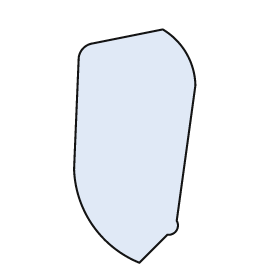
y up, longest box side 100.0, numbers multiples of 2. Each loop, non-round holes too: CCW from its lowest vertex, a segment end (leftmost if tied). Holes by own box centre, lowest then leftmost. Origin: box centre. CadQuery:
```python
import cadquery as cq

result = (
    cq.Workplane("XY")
    .moveTo(2.0, -50.0)
    .lineTo(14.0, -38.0)
    .threePointArc((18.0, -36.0), (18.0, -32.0))
    .lineTo(26.0, 26.0)
    .threePointArc((22.0, 40.0), (12.0, 50.0))
    .lineTo(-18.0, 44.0)
    .threePointArc((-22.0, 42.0), (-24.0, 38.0))
    .lineTo(-26.0, -10.0)
    .threePointArc((-18.0, -34.0), (2.0, -50.0))
    .close()
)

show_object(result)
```